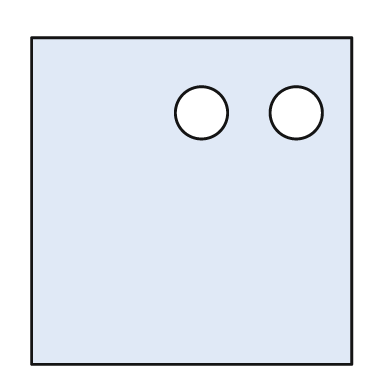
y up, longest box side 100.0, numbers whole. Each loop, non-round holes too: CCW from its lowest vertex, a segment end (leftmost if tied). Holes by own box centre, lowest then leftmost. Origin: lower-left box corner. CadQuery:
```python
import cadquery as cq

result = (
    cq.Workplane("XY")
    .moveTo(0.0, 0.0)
    .lineTo(98.0, 0.0)
    .lineTo(98.0, 100.0)
    .lineTo(0.0, 100.0)
    .close()
    .moveTo(52.0, 77.0)
    .circle(8.0)
    .moveTo(81.0, 77.0)
    .circle(8.0)
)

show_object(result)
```